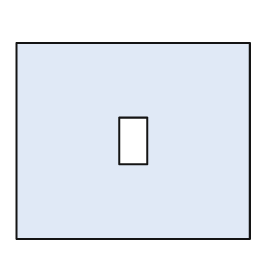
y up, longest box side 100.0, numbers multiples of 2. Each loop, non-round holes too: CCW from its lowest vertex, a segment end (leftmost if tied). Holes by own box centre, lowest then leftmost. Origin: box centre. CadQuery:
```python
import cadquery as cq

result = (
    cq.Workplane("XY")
    .moveTo(-50.0, -42.0)
    .lineTo(50.0, -42.0)
    .lineTo(50.0, 42.0)
    .lineTo(-50.0, 42.0)
    .close()
    .moveTo(-6.0, -10.0)
    .lineTo(6.0, -10.0)
    .lineTo(6.0, 10.0)
    .lineTo(-6.0, 10.0)
    .close()
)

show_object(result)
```